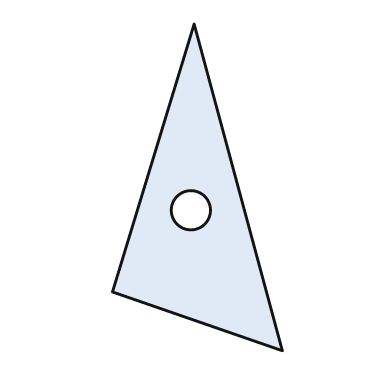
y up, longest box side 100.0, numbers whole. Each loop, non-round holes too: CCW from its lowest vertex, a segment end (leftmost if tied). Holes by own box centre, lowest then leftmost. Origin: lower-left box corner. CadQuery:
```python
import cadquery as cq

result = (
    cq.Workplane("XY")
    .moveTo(52.0, 0.0)
    .lineTo(25.0, 100.0)
    .lineTo(0.0, 18.0)
    .close()
    .moveTo(24.0, 43.0)
    .circle(6.0)
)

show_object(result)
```